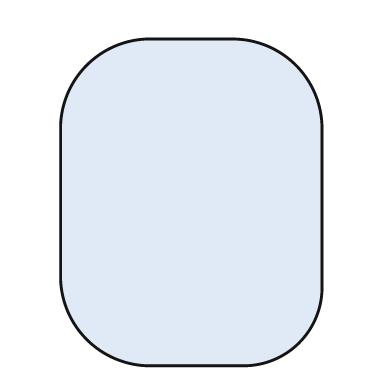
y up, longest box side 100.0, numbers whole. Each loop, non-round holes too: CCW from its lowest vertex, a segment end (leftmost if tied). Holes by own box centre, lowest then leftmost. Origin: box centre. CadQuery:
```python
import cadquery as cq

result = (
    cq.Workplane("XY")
    .moveTo(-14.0, -50.0)
    .lineTo(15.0, -50.0)
    .threePointArc((33.0, -43.0), (40.0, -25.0))
    .lineTo(40.0, 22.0)
    .threePointArc((32.0, 42.0), (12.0, 50.0))
    .lineTo(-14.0, 50.0)
    .threePointArc((-32.0, 42.0), (-40.0, 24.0))
    .lineTo(-40.0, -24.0)
    .threePointArc((-32.0, -42.0), (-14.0, -50.0))
    .close()
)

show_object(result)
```